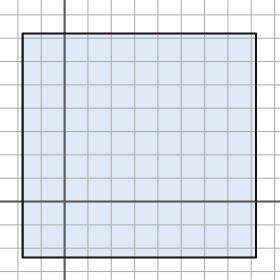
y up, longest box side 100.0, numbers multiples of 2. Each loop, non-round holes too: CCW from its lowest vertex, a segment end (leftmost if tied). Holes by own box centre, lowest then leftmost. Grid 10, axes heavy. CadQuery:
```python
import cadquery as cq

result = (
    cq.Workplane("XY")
    .moveTo(-18.0, -24.0)
    .lineTo(82.0, -24.0)
    .lineTo(82.0, 72.0)
    .lineTo(-18.0, 72.0)
    .close()
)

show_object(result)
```